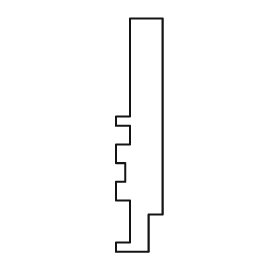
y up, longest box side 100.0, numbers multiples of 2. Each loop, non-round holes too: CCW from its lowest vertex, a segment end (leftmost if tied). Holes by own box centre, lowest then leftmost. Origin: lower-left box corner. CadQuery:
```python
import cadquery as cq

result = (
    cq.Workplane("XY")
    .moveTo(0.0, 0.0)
    .lineTo(14.0, 0.0)
    .lineTo(14.0, 16.0)
    .lineTo(20.0, 16.0)
    .lineTo(20.0, 100.0)
    .lineTo(6.0, 100.0)
    .lineTo(6.0, 58.0)
    .lineTo(0.0, 58.0)
    .lineTo(0.0, 54.0)
    .lineTo(6.0, 54.0)
    .lineTo(6.0, 46.0)
    .lineTo(0.0, 46.0)
    .lineTo(0.0, 38.0)
    .lineTo(4.0, 38.0)
    .lineTo(4.0, 30.0)
    .lineTo(0.0, 30.0)
    .lineTo(0.0, 22.0)
    .lineTo(6.0, 22.0)
    .lineTo(6.0, 4.0)
    .lineTo(0.0, 4.0)
    .close()
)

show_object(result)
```